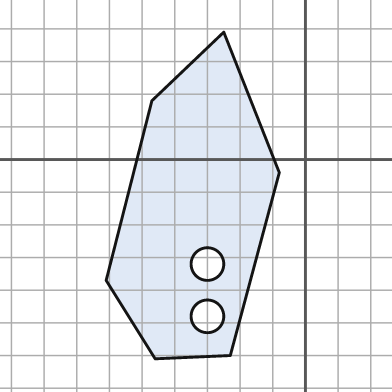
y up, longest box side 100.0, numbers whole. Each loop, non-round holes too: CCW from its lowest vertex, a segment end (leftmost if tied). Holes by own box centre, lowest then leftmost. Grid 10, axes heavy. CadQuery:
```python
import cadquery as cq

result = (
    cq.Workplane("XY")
    .moveTo(-46.0, -61.0)
    .lineTo(-23.0, -60.0)
    .lineTo(-8.0, -4.0)
    .lineTo(-25.0, 39.0)
    .lineTo(-47.0, 18.0)
    .lineTo(-61.0, -37.0)
    .close()
    .moveTo(-30.0, -48.0)
    .circle(5.0)
    .moveTo(-30.0, -32.0)
    .circle(5.0)
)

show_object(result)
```